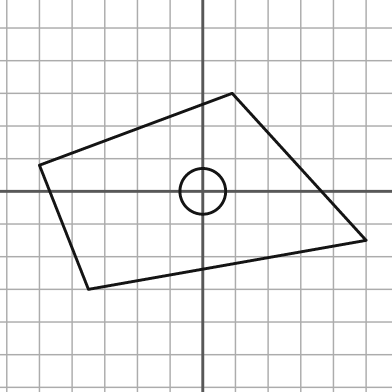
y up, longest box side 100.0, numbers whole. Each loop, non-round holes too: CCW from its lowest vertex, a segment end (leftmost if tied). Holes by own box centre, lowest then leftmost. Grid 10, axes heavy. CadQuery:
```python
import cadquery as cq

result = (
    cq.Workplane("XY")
    .moveTo(-35.0, -30.0)
    .lineTo(50.0, -15.0)
    .lineTo(9.0, 30.0)
    .lineTo(-50.0, 8.0)
    .close()
    .moveTo(0.0, 0.0)
    .circle(7.0)
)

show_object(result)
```